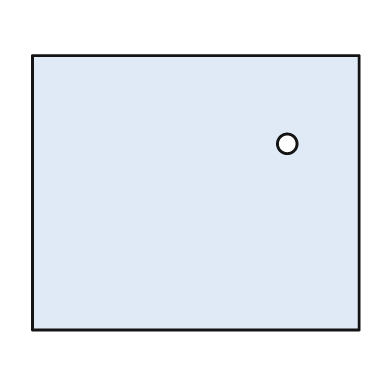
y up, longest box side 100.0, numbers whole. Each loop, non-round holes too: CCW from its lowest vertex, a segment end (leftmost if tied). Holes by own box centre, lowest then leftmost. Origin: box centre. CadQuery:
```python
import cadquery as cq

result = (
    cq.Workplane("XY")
    .moveTo(-50.0, -42.0)
    .lineTo(50.0, -42.0)
    .lineTo(50.0, 42.0)
    .lineTo(-50.0, 42.0)
    .close()
    .moveTo(28.0, 15.0)
    .circle(3.0)
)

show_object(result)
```